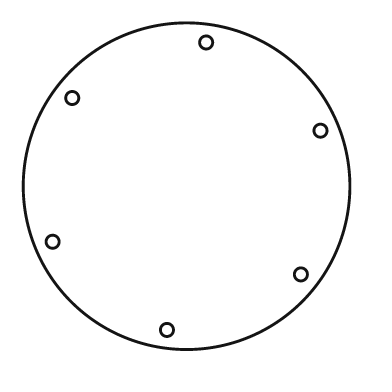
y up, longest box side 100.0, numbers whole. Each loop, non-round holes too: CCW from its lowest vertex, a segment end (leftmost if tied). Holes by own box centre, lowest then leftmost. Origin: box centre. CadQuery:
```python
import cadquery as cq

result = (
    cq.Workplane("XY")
    .moveTo(0.0, 0.0)
    .circle(50.0)
    .moveTo(-6.0, -44.0)
    .circle(2.0)
    .moveTo(35.0, -27.0)
    .circle(2.0)
    .moveTo(-41.0, -17.0)
    .circle(2.0)
    .moveTo(41.0, 17.0)
    .circle(2.0)
    .moveTo(-35.0, 27.0)
    .circle(2.0)
    .moveTo(6.0, 44.0)
    .circle(2.0)
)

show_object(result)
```